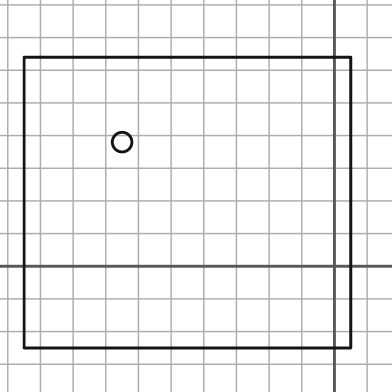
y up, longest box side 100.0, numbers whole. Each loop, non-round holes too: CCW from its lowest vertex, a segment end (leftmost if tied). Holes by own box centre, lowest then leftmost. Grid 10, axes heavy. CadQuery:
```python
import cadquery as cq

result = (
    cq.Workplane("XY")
    .moveTo(-95.0, -25.0)
    .lineTo(5.0, -25.0)
    .lineTo(5.0, 64.0)
    .lineTo(-95.0, 64.0)
    .close()
    .moveTo(-65.0, 38.0)
    .circle(3.0)
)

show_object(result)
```